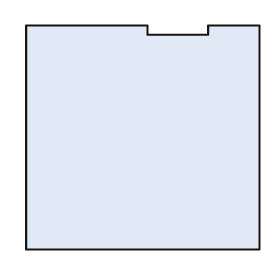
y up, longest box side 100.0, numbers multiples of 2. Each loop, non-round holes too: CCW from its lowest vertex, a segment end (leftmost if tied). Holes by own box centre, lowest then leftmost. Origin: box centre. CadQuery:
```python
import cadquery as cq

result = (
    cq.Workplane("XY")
    .moveTo(-50.0, -48.0)
    .lineTo(50.0, -48.0)
    .lineTo(50.0, 48.0)
    .lineTo(28.0, 48.0)
    .lineTo(28.0, 44.0)
    .lineTo(2.0, 44.0)
    .lineTo(2.0, 48.0)
    .lineTo(-50.0, 48.0)
    .close()
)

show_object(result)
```